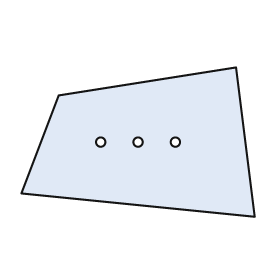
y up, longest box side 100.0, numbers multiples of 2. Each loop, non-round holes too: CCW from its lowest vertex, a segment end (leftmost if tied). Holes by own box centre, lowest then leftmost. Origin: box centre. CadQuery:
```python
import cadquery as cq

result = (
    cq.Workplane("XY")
    .moveTo(50.0, -32.0)
    .lineTo(42.0, 32.0)
    .lineTo(-34.0, 20.0)
    .lineTo(-50.0, -22.0)
    .close()
    .moveTo(-16.0, 0.0)
    .circle(2.0)
    .moveTo(0.0, 0.0)
    .circle(2.0)
    .moveTo(16.0, 0.0)
    .circle(2.0)
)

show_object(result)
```